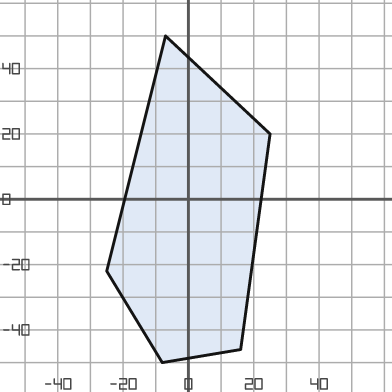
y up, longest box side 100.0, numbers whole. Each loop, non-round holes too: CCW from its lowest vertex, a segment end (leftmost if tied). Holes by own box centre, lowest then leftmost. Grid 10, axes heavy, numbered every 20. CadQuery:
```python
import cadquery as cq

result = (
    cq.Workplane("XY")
    .moveTo(-8.0, -50.0)
    .lineTo(16.0, -46.0)
    .lineTo(25.0, 20.0)
    .lineTo(-7.0, 50.0)
    .lineTo(-25.0, -22.0)
    .close()
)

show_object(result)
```